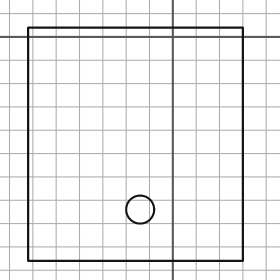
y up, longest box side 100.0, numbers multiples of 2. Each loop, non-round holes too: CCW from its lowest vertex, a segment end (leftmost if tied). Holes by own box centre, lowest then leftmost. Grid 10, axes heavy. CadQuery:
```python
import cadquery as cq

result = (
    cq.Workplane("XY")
    .moveTo(-62.0, -96.0)
    .lineTo(30.0, -96.0)
    .lineTo(30.0, 4.0)
    .lineTo(-62.0, 4.0)
    .close()
    .moveTo(-14.0, -74.0)
    .circle(6.0)
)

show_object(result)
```